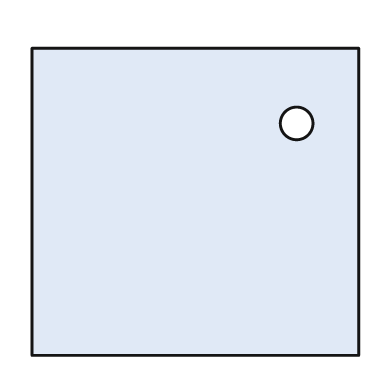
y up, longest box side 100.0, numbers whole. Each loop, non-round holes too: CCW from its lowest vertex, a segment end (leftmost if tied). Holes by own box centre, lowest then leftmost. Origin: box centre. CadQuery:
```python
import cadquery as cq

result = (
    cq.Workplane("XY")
    .moveTo(-50.0, -47.0)
    .lineTo(50.0, -47.0)
    .lineTo(50.0, 47.0)
    .lineTo(-50.0, 47.0)
    .close()
    .moveTo(31.0, 24.0)
    .circle(5.0)
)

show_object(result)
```